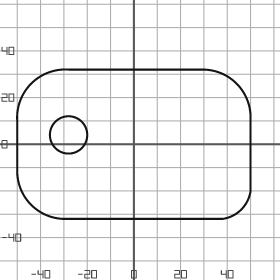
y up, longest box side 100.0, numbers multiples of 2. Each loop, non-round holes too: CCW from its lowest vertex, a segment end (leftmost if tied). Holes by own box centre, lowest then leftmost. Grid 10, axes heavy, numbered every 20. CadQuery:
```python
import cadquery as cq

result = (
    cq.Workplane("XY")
    .moveTo(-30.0, -32.0)
    .lineTo(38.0, -32.0)
    .threePointArc((46.0, -28.0), (50.0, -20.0))
    .lineTo(50.0, 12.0)
    .threePointArc((44.0, 26.0), (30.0, 32.0))
    .lineTo(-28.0, 32.0)
    .threePointArc((-44.0, 26.0), (-50.0, 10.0))
    .lineTo(-50.0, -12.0)
    .threePointArc((-44.0, -26.0), (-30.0, -32.0))
    .close()
    .moveTo(-28.0, 4.0)
    .circle(8.0)
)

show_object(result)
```